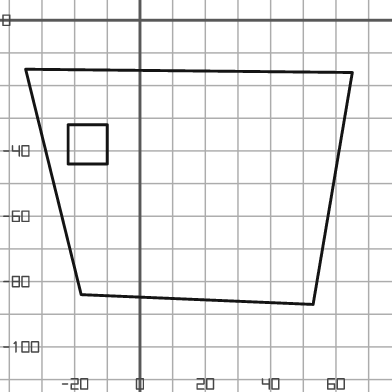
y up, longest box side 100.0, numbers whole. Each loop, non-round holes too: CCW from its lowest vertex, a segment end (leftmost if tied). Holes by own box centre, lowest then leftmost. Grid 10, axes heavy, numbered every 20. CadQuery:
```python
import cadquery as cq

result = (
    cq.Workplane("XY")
    .moveTo(53.0, -87.0)
    .lineTo(65.0, -16.0)
    .lineTo(-35.0, -15.0)
    .lineTo(-18.0, -84.0)
    .close()
    .moveTo(-22.0, -44.0)
    .lineTo(-10.0, -44.0)
    .lineTo(-10.0, -32.0)
    .lineTo(-22.0, -32.0)
    .close()
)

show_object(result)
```